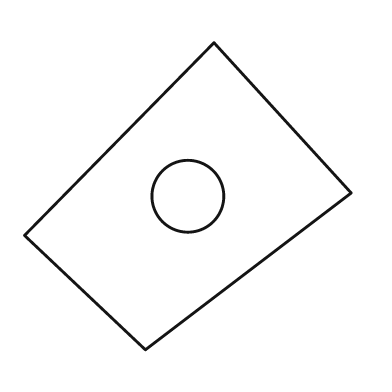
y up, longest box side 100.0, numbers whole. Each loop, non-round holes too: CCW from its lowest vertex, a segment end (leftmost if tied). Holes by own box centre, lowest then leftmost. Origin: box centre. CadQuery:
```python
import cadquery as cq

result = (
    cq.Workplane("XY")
    .moveTo(-13.0, -47.0)
    .lineTo(50.0, 1.0)
    .lineTo(8.0, 47.0)
    .lineTo(-50.0, -12.0)
    .close()
    .moveTo(0.0, 0.0)
    .circle(11.0)
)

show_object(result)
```